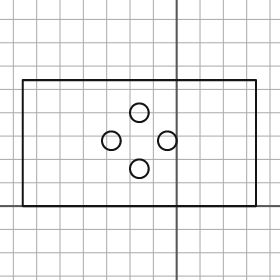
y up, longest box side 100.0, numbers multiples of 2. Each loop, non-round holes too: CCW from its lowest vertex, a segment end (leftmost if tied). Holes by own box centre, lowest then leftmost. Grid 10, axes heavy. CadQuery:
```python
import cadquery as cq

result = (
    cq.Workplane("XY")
    .moveTo(-66.0, 0.0)
    .lineTo(34.0, 0.0)
    .lineTo(34.0, 54.0)
    .lineTo(-66.0, 54.0)
    .close()
    .moveTo(-16.0, 16.0)
    .circle(4.0)
    .moveTo(-28.0, 28.0)
    .circle(4.0)
    .moveTo(-4.0, 28.0)
    .circle(4.0)
    .moveTo(-16.0, 40.0)
    .circle(4.0)
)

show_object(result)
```